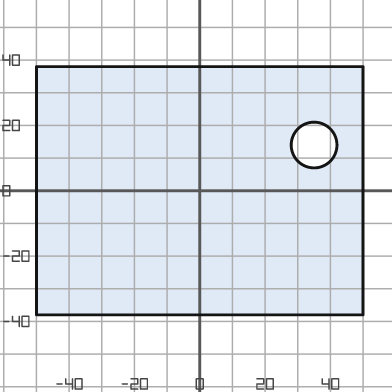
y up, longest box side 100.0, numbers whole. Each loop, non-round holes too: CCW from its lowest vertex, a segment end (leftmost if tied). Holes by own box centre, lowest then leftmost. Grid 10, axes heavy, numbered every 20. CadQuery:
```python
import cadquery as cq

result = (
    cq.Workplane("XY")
    .moveTo(-50.0, -38.0)
    .lineTo(50.0, -38.0)
    .lineTo(50.0, 38.0)
    .lineTo(-50.0, 38.0)
    .close()
    .moveTo(35.0, 14.0)
    .circle(7.0)
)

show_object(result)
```